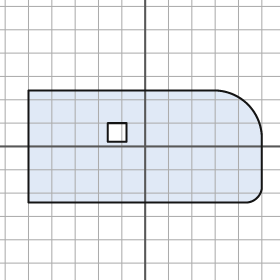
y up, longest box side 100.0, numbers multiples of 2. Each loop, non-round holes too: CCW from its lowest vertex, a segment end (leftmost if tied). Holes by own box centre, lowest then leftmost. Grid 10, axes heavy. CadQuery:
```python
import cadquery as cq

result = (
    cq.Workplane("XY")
    .moveTo(-50.0, -24.0)
    .lineTo(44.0, -24.0)
    .threePointArc((48.0, -22.0), (50.0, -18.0))
    .lineTo(50.0, 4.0)
    .threePointArc((44.0, 18.0), (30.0, 24.0))
    .lineTo(-50.0, 24.0)
    .close()
    .moveTo(-16.0, 2.0)
    .lineTo(-8.0, 2.0)
    .lineTo(-8.0, 10.0)
    .lineTo(-16.0, 10.0)
    .close()
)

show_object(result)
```